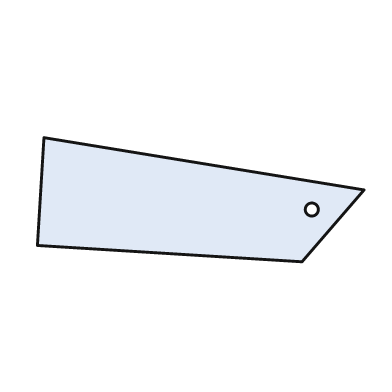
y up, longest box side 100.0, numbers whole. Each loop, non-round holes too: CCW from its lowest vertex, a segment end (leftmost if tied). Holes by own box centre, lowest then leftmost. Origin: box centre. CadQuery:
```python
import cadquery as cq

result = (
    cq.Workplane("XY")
    .moveTo(31.0, -19.0)
    .lineTo(50.0, 3.0)
    .lineTo(-48.0, 19.0)
    .lineTo(-50.0, -14.0)
    .close()
    .moveTo(34.0, -3.0)
    .circle(2.0)
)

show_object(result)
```